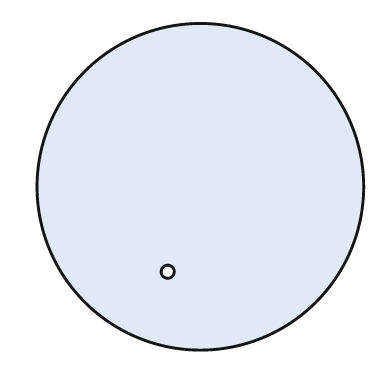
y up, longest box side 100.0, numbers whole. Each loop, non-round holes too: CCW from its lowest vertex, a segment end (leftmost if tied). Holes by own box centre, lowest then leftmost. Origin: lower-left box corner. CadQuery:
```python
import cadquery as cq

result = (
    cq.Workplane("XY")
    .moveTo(50.0, 50.0)
    .circle(50.0)
    .moveTo(40.0, 24.0)
    .circle(2.0)
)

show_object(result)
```